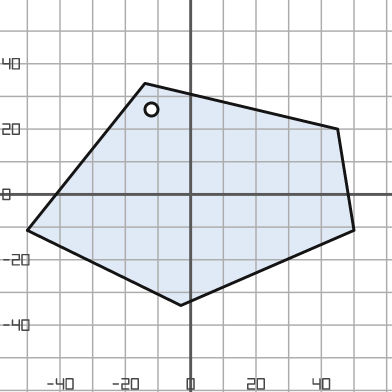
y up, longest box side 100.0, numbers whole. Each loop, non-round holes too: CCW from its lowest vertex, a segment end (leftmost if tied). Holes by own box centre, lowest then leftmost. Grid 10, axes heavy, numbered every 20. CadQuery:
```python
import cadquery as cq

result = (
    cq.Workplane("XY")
    .moveTo(-3.0, -34.0)
    .lineTo(50.0, -11.0)
    .lineTo(45.0, 20.0)
    .lineTo(-14.0, 34.0)
    .lineTo(-50.0, -11.0)
    .close()
    .moveTo(-12.0, 26.0)
    .circle(2.0)
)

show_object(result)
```